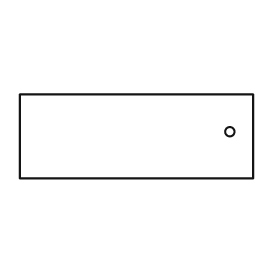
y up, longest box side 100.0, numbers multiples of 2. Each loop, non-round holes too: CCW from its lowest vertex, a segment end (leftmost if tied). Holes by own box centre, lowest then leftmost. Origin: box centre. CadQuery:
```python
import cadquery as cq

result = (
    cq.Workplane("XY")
    .moveTo(-50.0, -18.0)
    .lineTo(50.0, -18.0)
    .lineTo(50.0, 18.0)
    .lineTo(-50.0, 18.0)
    .close()
    .moveTo(40.0, 2.0)
    .circle(2.0)
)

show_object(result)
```